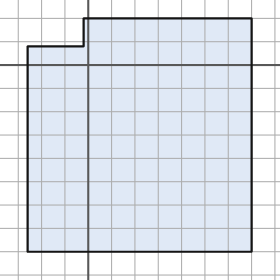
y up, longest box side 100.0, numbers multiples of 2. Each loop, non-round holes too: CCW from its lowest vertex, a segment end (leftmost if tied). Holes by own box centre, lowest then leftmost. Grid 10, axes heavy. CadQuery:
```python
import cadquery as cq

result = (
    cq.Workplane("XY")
    .moveTo(-26.0, -80.0)
    .lineTo(70.0, -80.0)
    .lineTo(70.0, 20.0)
    .lineTo(-2.0, 20.0)
    .lineTo(-2.0, 8.0)
    .lineTo(-26.0, 8.0)
    .close()
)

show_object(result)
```